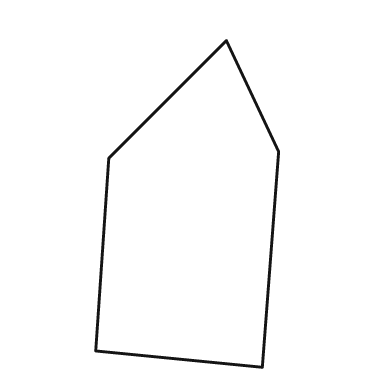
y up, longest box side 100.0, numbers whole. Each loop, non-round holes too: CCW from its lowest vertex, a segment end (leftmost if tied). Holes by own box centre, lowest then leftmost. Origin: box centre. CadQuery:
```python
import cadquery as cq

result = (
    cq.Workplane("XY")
    .moveTo(23.0, -50.0)
    .lineTo(28.0, 16.0)
    .lineTo(12.0, 50.0)
    .lineTo(-24.0, 14.0)
    .lineTo(-28.0, -45.0)
    .close()
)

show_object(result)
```